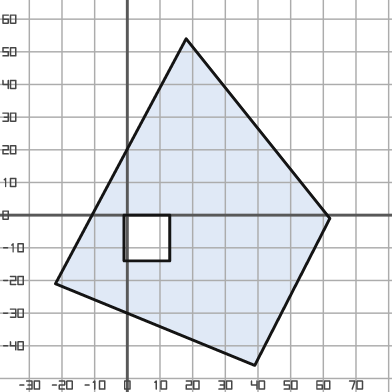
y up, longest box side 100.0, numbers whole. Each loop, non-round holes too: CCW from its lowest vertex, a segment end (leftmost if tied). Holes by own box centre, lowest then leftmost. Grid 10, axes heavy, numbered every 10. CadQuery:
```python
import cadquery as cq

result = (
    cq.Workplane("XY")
    .moveTo(39.0, -46.0)
    .lineTo(62.0, -1.0)
    .lineTo(18.0, 54.0)
    .lineTo(-22.0, -21.0)
    .close()
    .moveTo(-1.0, -14.0)
    .lineTo(13.0, -14.0)
    .lineTo(13.0, 0.0)
    .lineTo(-1.0, 0.0)
    .close()
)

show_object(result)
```